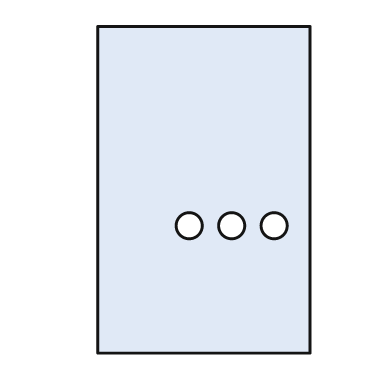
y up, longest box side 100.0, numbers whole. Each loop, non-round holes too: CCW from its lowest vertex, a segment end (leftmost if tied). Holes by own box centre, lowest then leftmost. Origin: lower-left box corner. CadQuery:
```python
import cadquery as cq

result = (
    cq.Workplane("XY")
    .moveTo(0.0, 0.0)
    .lineTo(65.0, 0.0)
    .lineTo(65.0, 100.0)
    .lineTo(0.0, 100.0)
    .close()
    .moveTo(28.0, 39.0)
    .circle(4.0)
    .moveTo(41.0, 39.0)
    .circle(4.0)
    .moveTo(54.0, 39.0)
    .circle(4.0)
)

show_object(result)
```